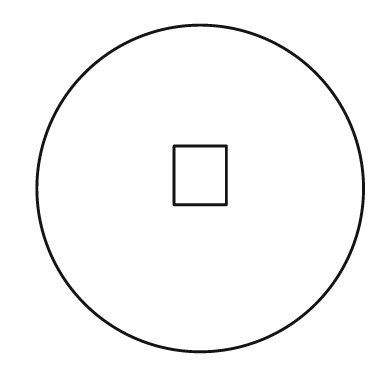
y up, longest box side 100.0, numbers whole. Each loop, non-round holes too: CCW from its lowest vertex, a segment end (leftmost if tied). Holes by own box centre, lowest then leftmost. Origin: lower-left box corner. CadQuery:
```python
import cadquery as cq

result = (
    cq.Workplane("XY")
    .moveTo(50.0, 50.0)
    .circle(50.0)
    .moveTo(42.0, 45.0)
    .lineTo(58.0, 45.0)
    .lineTo(58.0, 63.0)
    .lineTo(42.0, 63.0)
    .close()
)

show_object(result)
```